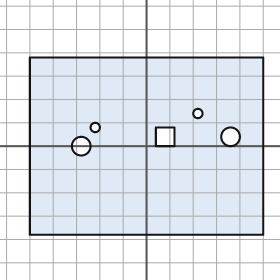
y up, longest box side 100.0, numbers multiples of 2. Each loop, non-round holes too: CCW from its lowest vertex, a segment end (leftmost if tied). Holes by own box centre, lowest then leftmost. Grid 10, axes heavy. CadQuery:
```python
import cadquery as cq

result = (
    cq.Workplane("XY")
    .moveTo(-50.0, -38.0)
    .lineTo(50.0, -38.0)
    .lineTo(50.0, 38.0)
    .lineTo(-50.0, 38.0)
    .close()
    .moveTo(-28.0, 0.0)
    .circle(4.0)
    .moveTo(4.0, 0.0)
    .lineTo(12.0, 0.0)
    .lineTo(12.0, 8.0)
    .lineTo(4.0, 8.0)
    .close()
    .moveTo(36.0, 4.0)
    .circle(4.0)
    .moveTo(-22.0, 8.0)
    .circle(2.0)
    .moveTo(22.0, 14.0)
    .circle(2.0)
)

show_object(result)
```